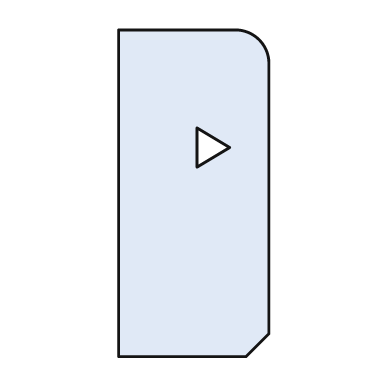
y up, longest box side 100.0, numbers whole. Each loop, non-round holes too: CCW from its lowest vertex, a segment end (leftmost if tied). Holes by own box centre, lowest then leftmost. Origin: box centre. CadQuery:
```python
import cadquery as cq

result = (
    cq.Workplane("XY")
    .moveTo(-23.0, -50.0)
    .lineTo(16.0, -50.0)
    .lineTo(23.0, -43.0)
    .lineTo(23.0, 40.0)
    .threePointArc((20.0, 47.0), (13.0, 50.0))
    .lineTo(-23.0, 50.0)
    .close()
    .moveTo(1.0, 8.0)
    .lineTo(11.0, 14.0)
    .lineTo(1.0, 20.0)
    .close()
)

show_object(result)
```